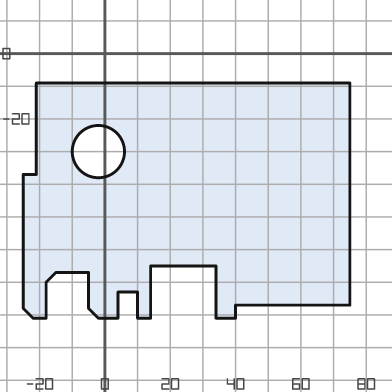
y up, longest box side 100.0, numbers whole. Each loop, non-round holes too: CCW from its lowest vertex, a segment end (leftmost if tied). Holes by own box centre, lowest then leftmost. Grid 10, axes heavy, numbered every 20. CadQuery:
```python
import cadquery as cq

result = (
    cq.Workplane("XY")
    .moveTo(-22.0, -81.0)
    .lineTo(-18.0, -81.0)
    .lineTo(-18.0, -70.0)
    .lineTo(-15.0, -67.0)
    .lineTo(-5.0, -67.0)
    .lineTo(-5.0, -78.0)
    .lineTo(-2.0, -81.0)
    .lineTo(4.0, -81.0)
    .lineTo(4.0, -73.0)
    .lineTo(10.0, -73.0)
    .lineTo(10.0, -81.0)
    .lineTo(14.0, -81.0)
    .lineTo(14.0, -65.0)
    .lineTo(34.0, -65.0)
    .lineTo(34.0, -81.0)
    .lineTo(40.0, -81.0)
    .lineTo(40.0, -77.0)
    .lineTo(75.0, -77.0)
    .lineTo(75.0, -9.0)
    .lineTo(-21.0, -9.0)
    .lineTo(-21.0, -37.0)
    .lineTo(-25.0, -37.0)
    .lineTo(-25.0, -78.0)
    .close()
    .moveTo(-2.0, -30.0)
    .circle(8.0)
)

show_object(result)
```